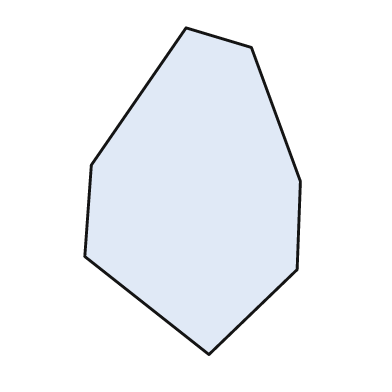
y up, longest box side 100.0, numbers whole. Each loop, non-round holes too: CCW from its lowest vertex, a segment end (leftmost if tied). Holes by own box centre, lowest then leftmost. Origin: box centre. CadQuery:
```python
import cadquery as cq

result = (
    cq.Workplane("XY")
    .moveTo(5.0, -50.0)
    .lineTo(32.0, -24.0)
    .lineTo(33.0, 3.0)
    .lineTo(18.0, 44.0)
    .lineTo(-2.0, 50.0)
    .lineTo(-31.0, 8.0)
    .lineTo(-33.0, -20.0)
    .close()
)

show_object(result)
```